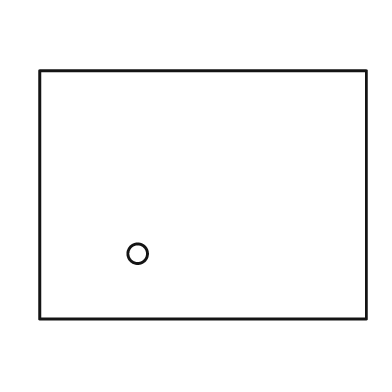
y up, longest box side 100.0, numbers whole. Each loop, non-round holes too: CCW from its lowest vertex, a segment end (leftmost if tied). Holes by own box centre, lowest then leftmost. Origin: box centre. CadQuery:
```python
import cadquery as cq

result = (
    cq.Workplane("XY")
    .moveTo(-50.0, -38.0)
    .lineTo(50.0, -38.0)
    .lineTo(50.0, 38.0)
    .lineTo(-50.0, 38.0)
    .close()
    .moveTo(-20.0, -18.0)
    .circle(3.0)
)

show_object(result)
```